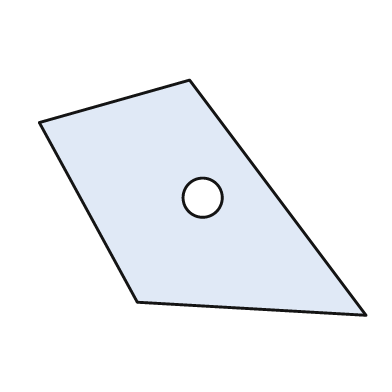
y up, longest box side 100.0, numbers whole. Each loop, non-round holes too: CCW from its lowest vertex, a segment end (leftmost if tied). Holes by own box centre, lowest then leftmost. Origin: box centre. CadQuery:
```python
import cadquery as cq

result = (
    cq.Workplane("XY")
    .moveTo(50.0, -36.0)
    .lineTo(-4.0, 36.0)
    .lineTo(-50.0, 23.0)
    .lineTo(-20.0, -32.0)
    .close()
    .moveTo(0.0, 0.0)
    .circle(6.0)
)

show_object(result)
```